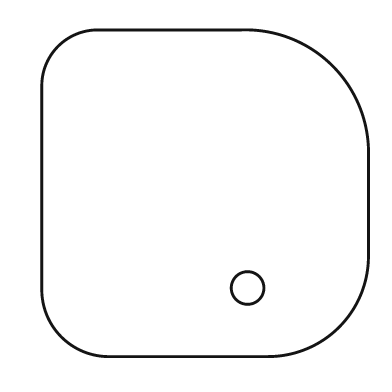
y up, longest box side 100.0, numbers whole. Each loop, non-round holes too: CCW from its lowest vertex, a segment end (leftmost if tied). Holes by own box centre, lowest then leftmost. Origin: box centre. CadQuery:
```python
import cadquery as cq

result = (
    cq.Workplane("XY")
    .moveTo(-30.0, -50.0)
    .lineTo(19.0, -50.0)
    .threePointArc((41.0, -41.0), (50.0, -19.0))
    .lineTo(50.0, 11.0)
    .threePointArc((39.0, 39.0), (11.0, 50.0))
    .lineTo(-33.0, 50.0)
    .threePointArc((-45.0, 45.0), (-50.0, 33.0))
    .lineTo(-50.0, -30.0)
    .threePointArc((-44.0, -44.0), (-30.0, -50.0))
    .close()
    .moveTo(13.0, -29.0)
    .circle(5.0)
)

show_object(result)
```